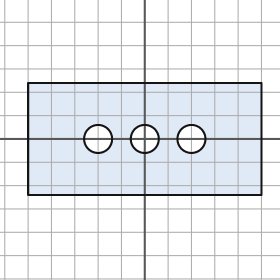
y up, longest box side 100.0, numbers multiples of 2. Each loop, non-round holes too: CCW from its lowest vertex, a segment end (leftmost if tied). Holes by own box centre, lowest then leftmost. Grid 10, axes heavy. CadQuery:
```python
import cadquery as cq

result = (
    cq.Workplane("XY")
    .moveTo(-50.0, -24.0)
    .lineTo(50.0, -24.0)
    .lineTo(50.0, 24.0)
    .lineTo(-50.0, 24.0)
    .close()
    .moveTo(-20.0, 0.0)
    .circle(6.0)
    .moveTo(0.0, 0.0)
    .circle(6.0)
    .moveTo(20.0, 0.0)
    .circle(6.0)
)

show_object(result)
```